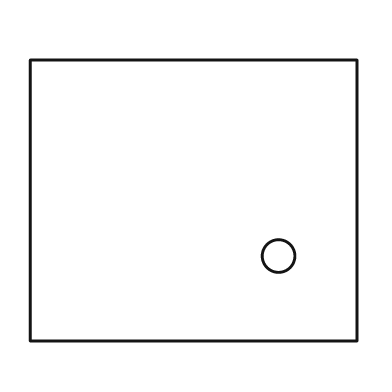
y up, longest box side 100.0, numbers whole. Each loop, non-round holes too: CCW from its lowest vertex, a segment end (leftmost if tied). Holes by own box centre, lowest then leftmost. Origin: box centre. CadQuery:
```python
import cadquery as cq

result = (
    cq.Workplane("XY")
    .moveTo(-50.0, -43.0)
    .lineTo(50.0, -43.0)
    .lineTo(50.0, 43.0)
    .lineTo(-50.0, 43.0)
    .close()
    .moveTo(26.0, -17.0)
    .circle(5.0)
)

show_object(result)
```